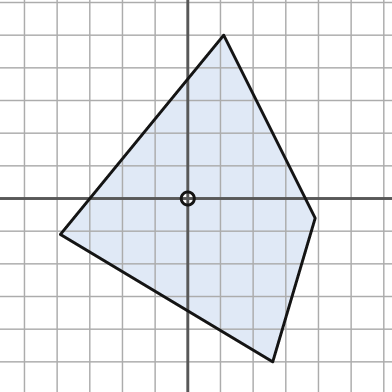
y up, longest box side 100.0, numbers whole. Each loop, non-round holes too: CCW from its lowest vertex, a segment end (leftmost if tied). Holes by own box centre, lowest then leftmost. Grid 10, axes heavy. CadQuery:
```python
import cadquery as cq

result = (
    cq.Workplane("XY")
    .moveTo(26.0, -50.0)
    .lineTo(39.0, -6.0)
    .lineTo(11.0, 50.0)
    .lineTo(-39.0, -11.0)
    .close()
    .moveTo(0.0, 0.0)
    .circle(2.0)
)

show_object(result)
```